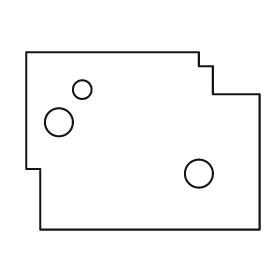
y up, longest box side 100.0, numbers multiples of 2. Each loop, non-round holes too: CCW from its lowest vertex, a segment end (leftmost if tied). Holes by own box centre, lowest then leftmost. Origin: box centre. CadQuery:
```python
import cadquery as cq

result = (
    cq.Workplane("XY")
    .moveTo(-44.0, -38.0)
    .lineTo(50.0, -38.0)
    .lineTo(50.0, 20.0)
    .lineTo(30.0, 20.0)
    .lineTo(30.0, 32.0)
    .lineTo(24.0, 32.0)
    .lineTo(24.0, 38.0)
    .lineTo(-50.0, 38.0)
    .lineTo(-50.0, -12.0)
    .lineTo(-44.0, -12.0)
    .close()
    .moveTo(24.0, -14.0)
    .circle(6.0)
    .moveTo(-36.0, 8.0)
    .circle(6.0)
    .moveTo(-26.0, 22.0)
    .circle(4.0)
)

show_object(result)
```